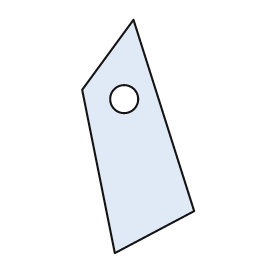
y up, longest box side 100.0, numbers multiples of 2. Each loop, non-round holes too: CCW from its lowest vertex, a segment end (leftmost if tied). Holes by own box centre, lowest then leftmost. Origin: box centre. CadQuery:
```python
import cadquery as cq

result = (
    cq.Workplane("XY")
    .moveTo(-10.0, -50.0)
    .lineTo(24.0, -32.0)
    .lineTo(-2.0, 50.0)
    .lineTo(-24.0, 20.0)
    .close()
    .moveTo(-6.0, 16.0)
    .circle(6.0)
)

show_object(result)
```